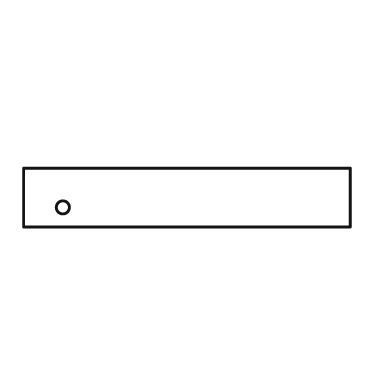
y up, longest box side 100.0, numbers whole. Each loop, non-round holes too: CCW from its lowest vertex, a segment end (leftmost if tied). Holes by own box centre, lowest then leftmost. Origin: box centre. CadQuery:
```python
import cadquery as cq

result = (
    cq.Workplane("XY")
    .moveTo(-50.0, -9.0)
    .lineTo(50.0, -9.0)
    .lineTo(50.0, 9.0)
    .lineTo(-50.0, 9.0)
    .close()
    .moveTo(-38.0, -3.0)
    .circle(2.0)
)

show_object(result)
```